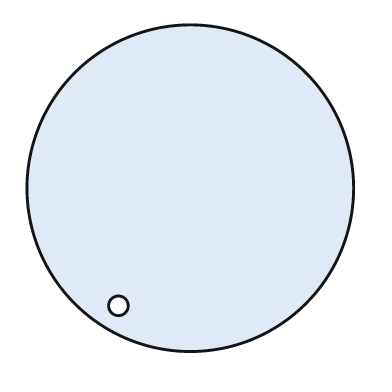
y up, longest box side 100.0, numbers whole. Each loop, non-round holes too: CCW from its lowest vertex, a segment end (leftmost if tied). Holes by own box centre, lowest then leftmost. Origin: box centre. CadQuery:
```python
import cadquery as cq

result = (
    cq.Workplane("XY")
    .moveTo(0.0, 0.0)
    .circle(50.0)
    .moveTo(-22.0, -36.0)
    .circle(3.0)
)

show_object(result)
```